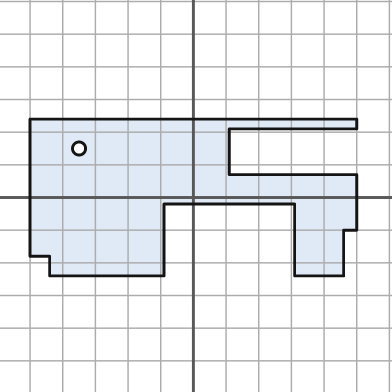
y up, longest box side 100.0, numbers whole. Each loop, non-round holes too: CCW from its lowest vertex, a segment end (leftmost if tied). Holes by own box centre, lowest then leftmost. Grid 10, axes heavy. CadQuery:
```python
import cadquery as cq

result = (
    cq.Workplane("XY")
    .moveTo(-44.0, -24.0)
    .lineTo(-9.0, -24.0)
    .lineTo(-9.0, -2.0)
    .lineTo(31.0, -2.0)
    .lineTo(31.0, -24.0)
    .lineTo(46.0, -24.0)
    .lineTo(46.0, -10.0)
    .lineTo(50.0, -10.0)
    .lineTo(50.0, 7.0)
    .lineTo(11.0, 7.0)
    .lineTo(11.0, 21.0)
    .lineTo(50.0, 21.0)
    .lineTo(50.0, 24.0)
    .lineTo(-50.0, 24.0)
    .lineTo(-50.0, -18.0)
    .lineTo(-44.0, -18.0)
    .close()
    .moveTo(-35.0, 15.0)
    .circle(2.0)
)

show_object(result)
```